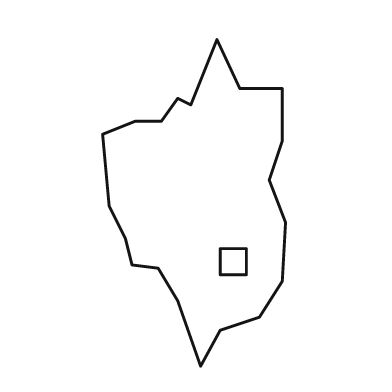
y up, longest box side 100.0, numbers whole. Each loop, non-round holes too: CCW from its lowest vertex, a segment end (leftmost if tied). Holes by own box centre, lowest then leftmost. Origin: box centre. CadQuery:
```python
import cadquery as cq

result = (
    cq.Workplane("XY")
    .moveTo(2.0, -50.0)
    .lineTo(8.0, -39.0)
    .lineTo(20.0, -35.0)
    .lineTo(27.0, -24.0)
    .lineTo(28.0, -6.0)
    .lineTo(23.0, 7.0)
    .lineTo(27.0, 19.0)
    .lineTo(27.0, 35.0)
    .lineTo(14.0, 35.0)
    .lineTo(7.0, 50.0)
    .lineTo(-1.0, 30.0)
    .lineTo(-5.0, 32.0)
    .lineTo(-10.0, 25.0)
    .lineTo(-18.0, 25.0)
    .lineTo(-28.0, 21.0)
    .lineTo(-26.0, -1.0)
    .lineTo(-21.0, -11.0)
    .lineTo(-19.0, -19.0)
    .lineTo(-11.0, -20.0)
    .lineTo(-5.0, -30.0)
    .close()
    .moveTo(8.0, -22.0)
    .lineTo(16.0, -22.0)
    .lineTo(16.0, -14.0)
    .lineTo(8.0, -14.0)
    .close()
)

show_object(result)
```